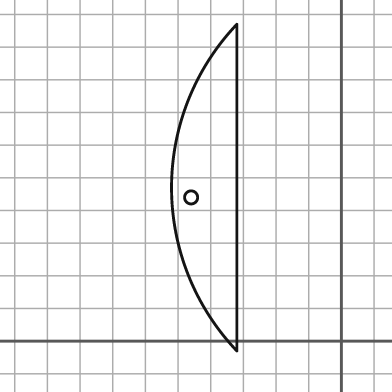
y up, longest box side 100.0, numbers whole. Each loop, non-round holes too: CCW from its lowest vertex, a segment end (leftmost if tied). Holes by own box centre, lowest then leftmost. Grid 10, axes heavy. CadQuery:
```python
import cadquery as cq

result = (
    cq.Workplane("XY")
    .moveTo(-32.0, -3.0)
    .lineTo(-32.0, 97.0)
    .threePointArc((-52.0, 47.0), (-32.0, -3.0))
    .close()
    .moveTo(-46.0, 44.0)
    .circle(2.0)
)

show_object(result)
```